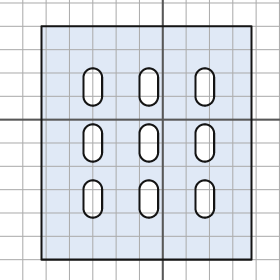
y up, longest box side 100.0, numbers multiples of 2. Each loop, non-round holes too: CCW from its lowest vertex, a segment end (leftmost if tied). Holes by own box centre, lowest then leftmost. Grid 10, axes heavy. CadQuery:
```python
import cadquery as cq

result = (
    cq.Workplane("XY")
    .moveTo(-52.0, -60.0)
    .lineTo(38.0, -60.0)
    .lineTo(38.0, 40.0)
    .lineTo(-52.0, 40.0)
    .close()
    .moveTo(-34.0, -38.0)
    .threePointArc((-30.0, -42.0), (-26.0, -38.0))
    .lineTo(-26.0, -30.0)
    .threePointArc((-30.0, -26.0), (-34.0, -30.0))
    .close()
    .moveTo(-10.0, -38.0)
    .threePointArc((-6.0, -42.0), (-2.0, -38.0))
    .lineTo(-2.0, -30.0)
    .threePointArc((-6.0, -26.0), (-10.0, -30.0))
    .close()
    .moveTo(14.0, -38.0)
    .threePointArc((18.0, -42.0), (22.0, -38.0))
    .lineTo(22.0, -30.0)
    .threePointArc((18.0, -26.0), (14.0, -30.0))
    .close()
    .moveTo(-34.0, -14.0)
    .threePointArc((-30.0, -18.0), (-26.0, -14.0))
    .lineTo(-26.0, -6.0)
    .threePointArc((-30.0, -2.0), (-34.0, -6.0))
    .close()
    .moveTo(-10.0, -14.0)
    .threePointArc((-6.0, -18.0), (-2.0, -14.0))
    .lineTo(-2.0, -6.0)
    .threePointArc((-6.0, -2.0), (-10.0, -6.0))
    .close()
    .moveTo(14.0, -14.0)
    .threePointArc((18.0, -18.0), (22.0, -14.0))
    .lineTo(22.0, -6.0)
    .threePointArc((18.0, -2.0), (14.0, -6.0))
    .close()
    .moveTo(-34.0, 10.0)
    .threePointArc((-30.0, 6.0), (-26.0, 10.0))
    .lineTo(-26.0, 18.0)
    .threePointArc((-30.0, 22.0), (-34.0, 18.0))
    .close()
    .moveTo(-10.0, 10.0)
    .threePointArc((-6.0, 6.0), (-2.0, 10.0))
    .lineTo(-2.0, 18.0)
    .threePointArc((-6.0, 22.0), (-10.0, 18.0))
    .close()
    .moveTo(14.0, 10.0)
    .threePointArc((18.0, 6.0), (22.0, 10.0))
    .lineTo(22.0, 18.0)
    .threePointArc((18.0, 22.0), (14.0, 18.0))
    .close()
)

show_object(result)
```